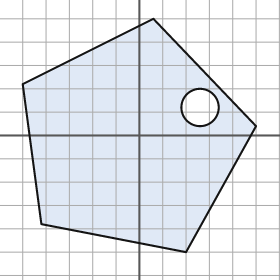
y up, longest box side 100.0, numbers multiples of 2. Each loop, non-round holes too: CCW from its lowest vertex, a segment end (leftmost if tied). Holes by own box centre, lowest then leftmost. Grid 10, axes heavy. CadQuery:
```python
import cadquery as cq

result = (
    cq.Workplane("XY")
    .moveTo(20.0, -50.0)
    .lineTo(50.0, 4.0)
    .lineTo(6.0, 50.0)
    .lineTo(-50.0, 22.0)
    .lineTo(-42.0, -38.0)
    .close()
    .moveTo(26.0, 12.0)
    .circle(8.0)
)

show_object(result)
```